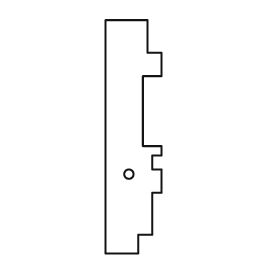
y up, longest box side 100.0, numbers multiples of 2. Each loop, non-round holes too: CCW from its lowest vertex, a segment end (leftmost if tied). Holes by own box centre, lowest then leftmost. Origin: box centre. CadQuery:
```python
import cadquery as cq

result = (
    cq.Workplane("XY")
    .moveTo(-12.0, -50.0)
    .lineTo(2.0, -50.0)
    .lineTo(2.0, -42.0)
    .lineTo(8.0, -42.0)
    .lineTo(8.0, -24.0)
    .lineTo(12.0, -24.0)
    .lineTo(12.0, -14.0)
    .lineTo(8.0, -14.0)
    .lineTo(8.0, -8.0)
    .lineTo(12.0, -8.0)
    .lineTo(12.0, -4.0)
    .lineTo(4.0, -4.0)
    .lineTo(4.0, 26.0)
    .lineTo(12.0, 26.0)
    .lineTo(12.0, 36.0)
    .lineTo(6.0, 36.0)
    .lineTo(6.0, 50.0)
    .lineTo(-12.0, 50.0)
    .close()
    .moveTo(-2.0, -16.0)
    .circle(2.0)
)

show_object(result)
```